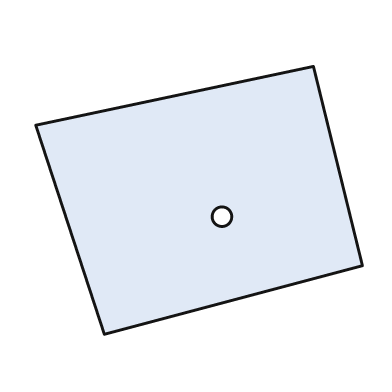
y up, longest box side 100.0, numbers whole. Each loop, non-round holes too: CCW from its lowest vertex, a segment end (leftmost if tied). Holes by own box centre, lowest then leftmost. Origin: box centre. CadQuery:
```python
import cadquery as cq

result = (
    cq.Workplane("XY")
    .moveTo(-29.0, -41.0)
    .lineTo(50.0, -20.0)
    .lineTo(35.0, 41.0)
    .lineTo(-50.0, 23.0)
    .close()
    .moveTo(7.0, -5.0)
    .circle(3.0)
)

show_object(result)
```